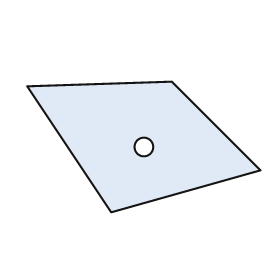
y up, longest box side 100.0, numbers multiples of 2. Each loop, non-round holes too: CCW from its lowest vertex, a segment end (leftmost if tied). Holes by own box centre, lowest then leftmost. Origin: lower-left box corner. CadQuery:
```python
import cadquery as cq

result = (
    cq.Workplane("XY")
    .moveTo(36.0, 0.0)
    .lineTo(100.0, 18.0)
    .lineTo(62.0, 56.0)
    .lineTo(0.0, 54.0)
    .close()
    .moveTo(50.0, 28.0)
    .circle(4.0)
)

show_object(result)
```